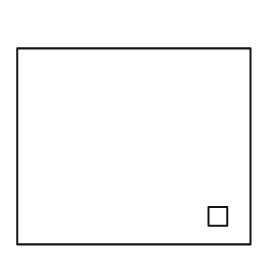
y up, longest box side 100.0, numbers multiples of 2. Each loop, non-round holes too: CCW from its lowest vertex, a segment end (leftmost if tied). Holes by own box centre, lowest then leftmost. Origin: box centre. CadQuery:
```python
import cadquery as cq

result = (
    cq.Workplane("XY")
    .moveTo(-50.0, -42.0)
    .lineTo(50.0, -42.0)
    .lineTo(50.0, 42.0)
    .lineTo(-50.0, 42.0)
    .close()
    .moveTo(32.0, -34.0)
    .lineTo(40.0, -34.0)
    .lineTo(40.0, -26.0)
    .lineTo(32.0, -26.0)
    .close()
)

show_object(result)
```